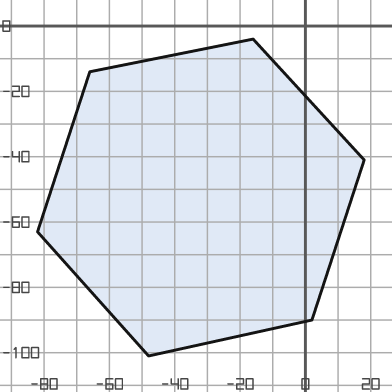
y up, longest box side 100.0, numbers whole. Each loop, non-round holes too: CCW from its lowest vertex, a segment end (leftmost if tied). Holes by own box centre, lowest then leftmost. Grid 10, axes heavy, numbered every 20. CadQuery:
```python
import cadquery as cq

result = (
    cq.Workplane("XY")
    .moveTo(-48.0, -101.0)
    .lineTo(2.0, -90.0)
    .lineTo(18.0, -41.0)
    .lineTo(-16.0, -4.0)
    .lineTo(-66.0, -14.0)
    .lineTo(-82.0, -63.0)
    .close()
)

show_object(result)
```